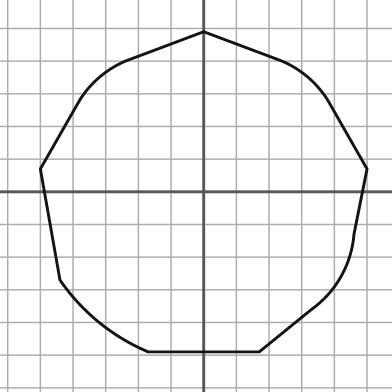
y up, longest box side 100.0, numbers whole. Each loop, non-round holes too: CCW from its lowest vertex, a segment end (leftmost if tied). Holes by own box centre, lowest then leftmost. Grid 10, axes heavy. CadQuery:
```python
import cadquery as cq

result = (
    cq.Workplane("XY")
    .moveTo(-17.0, -49.0)
    .lineTo(17.0, -49.0)
    .lineTo(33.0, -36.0)
    .threePointArc((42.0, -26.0), (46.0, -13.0))
    .lineTo(50.0, 7.0)
    .lineTo(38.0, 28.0)
    .threePointArc((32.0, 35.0), (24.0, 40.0))
    .lineTo(0.0, 49.0)
    .lineTo(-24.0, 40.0)
    .threePointArc((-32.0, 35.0), (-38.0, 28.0))
    .lineTo(-50.0, 7.0)
    .lineTo(-44.0, -27.0)
    .threePointArc((-32.0, -40.0), (-17.0, -49.0))
    .close()
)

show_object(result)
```